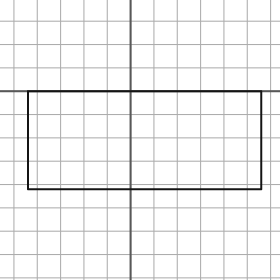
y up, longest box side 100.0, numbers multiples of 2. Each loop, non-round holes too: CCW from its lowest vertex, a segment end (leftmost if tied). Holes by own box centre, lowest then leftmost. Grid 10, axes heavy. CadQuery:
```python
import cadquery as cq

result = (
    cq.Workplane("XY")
    .moveTo(-44.0, -42.0)
    .lineTo(56.0, -42.0)
    .lineTo(56.0, 0.0)
    .lineTo(-44.0, 0.0)
    .close()
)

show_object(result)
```